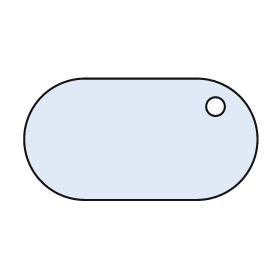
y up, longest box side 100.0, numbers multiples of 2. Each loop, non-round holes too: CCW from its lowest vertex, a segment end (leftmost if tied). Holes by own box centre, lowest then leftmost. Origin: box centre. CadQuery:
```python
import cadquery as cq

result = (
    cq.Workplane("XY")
    .moveTo(-24.0, -26.0)
    .lineTo(24.0, -26.0)
    .threePointArc((50.0, 0.0), (24.0, 26.0))
    .lineTo(-24.0, 26.0)
    .threePointArc((-50.0, 0.0), (-24.0, -26.0))
    .close()
    .moveTo(32.0, 14.0)
    .circle(4.0)
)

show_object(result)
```